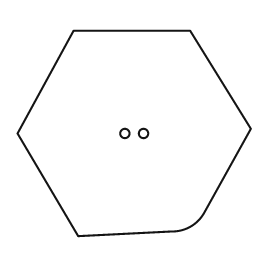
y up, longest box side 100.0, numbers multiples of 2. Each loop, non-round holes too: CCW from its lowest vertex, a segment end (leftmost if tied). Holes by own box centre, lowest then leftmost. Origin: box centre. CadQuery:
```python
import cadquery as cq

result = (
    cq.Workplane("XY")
    .moveTo(-24.0, -44.0)
    .lineTo(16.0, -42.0)
    .threePointArc((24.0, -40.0), (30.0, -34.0))
    .lineTo(50.0, 2.0)
    .lineTo(24.0, 44.0)
    .lineTo(-26.0, 44.0)
    .lineTo(-50.0, 0.0)
    .close()
    .moveTo(-4.0, 0.0)
    .circle(2.0)
    .moveTo(4.0, 0.0)
    .circle(2.0)
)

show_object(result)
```